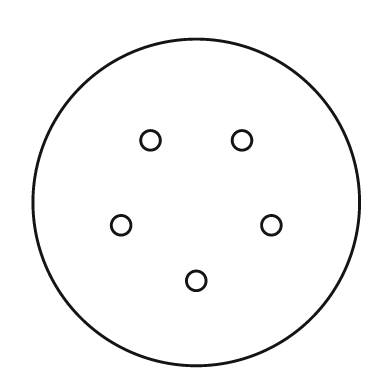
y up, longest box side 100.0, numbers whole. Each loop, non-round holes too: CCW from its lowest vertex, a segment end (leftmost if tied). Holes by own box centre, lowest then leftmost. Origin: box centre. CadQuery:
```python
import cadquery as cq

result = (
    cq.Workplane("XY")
    .moveTo(0.0, 0.0)
    .circle(50.0)
    .moveTo(0.0, -24.0)
    .circle(3.0)
    .moveTo(-23.0, -7.0)
    .circle(3.0)
    .moveTo(23.0, -7.0)
    .circle(3.0)
    .moveTo(-14.0, 19.0)
    .circle(3.0)
    .moveTo(14.0, 19.0)
    .circle(3.0)
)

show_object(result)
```